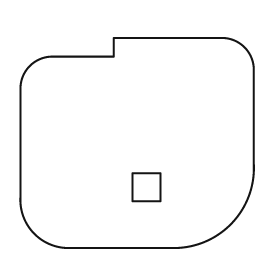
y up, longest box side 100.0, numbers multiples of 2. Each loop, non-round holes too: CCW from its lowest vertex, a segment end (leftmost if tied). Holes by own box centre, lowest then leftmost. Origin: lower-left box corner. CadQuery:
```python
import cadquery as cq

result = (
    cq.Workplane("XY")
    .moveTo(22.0, 0.0)
    .lineTo(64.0, 0.0)
    .threePointArc((90.0, 10.0), (100.0, 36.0))
    .lineTo(100.0, 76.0)
    .threePointArc((96.0, 86.0), (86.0, 90.0))
    .lineTo(40.0, 90.0)
    .lineTo(40.0, 82.0)
    .lineTo(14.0, 82.0)
    .threePointArc((4.0, 78.0), (0.0, 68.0))
    .lineTo(0.0, 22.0)
    .threePointArc((6.0, 6.0), (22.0, 0.0))
    .close()
    .moveTo(48.0, 20.0)
    .lineTo(60.0, 20.0)
    .lineTo(60.0, 32.0)
    .lineTo(48.0, 32.0)
    .close()
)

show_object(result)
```